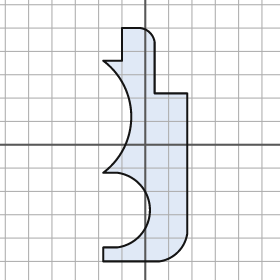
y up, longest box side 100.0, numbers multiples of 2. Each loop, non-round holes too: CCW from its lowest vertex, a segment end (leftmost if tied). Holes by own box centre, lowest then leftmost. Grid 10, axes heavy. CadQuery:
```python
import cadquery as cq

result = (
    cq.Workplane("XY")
    .moveTo(-18.0, -50.0)
    .lineTo(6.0, -50.0)
    .threePointArc((14.0, -46.0), (18.0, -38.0))
    .lineTo(18.0, 22.0)
    .lineTo(4.0, 22.0)
    .lineTo(4.0, 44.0)
    .threePointArc((2.0, 48.0), (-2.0, 50.0))
    .lineTo(-10.0, 50.0)
    .lineTo(-10.0, 36.0)
    .lineTo(-18.0, 36.0)
    .threePointArc((-6.0, 12.0), (-18.0, -12.0))
    .lineTo(-12.0, -12.0)
    .threePointArc((2.0, -28.0), (-12.0, -44.0))
    .lineTo(-18.0, -44.0)
    .close()
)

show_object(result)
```